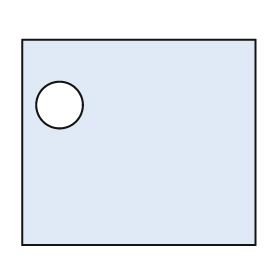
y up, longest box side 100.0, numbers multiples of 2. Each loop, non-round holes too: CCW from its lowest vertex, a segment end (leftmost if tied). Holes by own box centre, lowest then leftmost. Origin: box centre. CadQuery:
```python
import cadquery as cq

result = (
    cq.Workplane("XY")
    .moveTo(-50.0, -44.0)
    .lineTo(50.0, -44.0)
    .lineTo(50.0, 44.0)
    .lineTo(-50.0, 44.0)
    .close()
    .moveTo(-34.0, 16.0)
    .circle(10.0)
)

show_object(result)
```